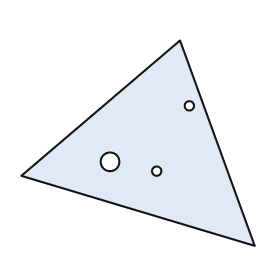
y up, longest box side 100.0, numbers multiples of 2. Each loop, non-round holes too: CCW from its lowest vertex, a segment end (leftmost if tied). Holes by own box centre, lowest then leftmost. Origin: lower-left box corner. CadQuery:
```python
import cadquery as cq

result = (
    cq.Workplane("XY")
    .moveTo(100.0, 0.0)
    .lineTo(68.0, 88.0)
    .lineTo(0.0, 30.0)
    .close()
    .moveTo(58.0, 32.0)
    .circle(2.0)
    .moveTo(38.0, 36.0)
    .circle(4.0)
    .moveTo(72.0, 60.0)
    .circle(2.0)
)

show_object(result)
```